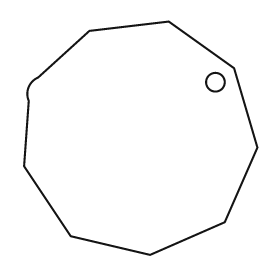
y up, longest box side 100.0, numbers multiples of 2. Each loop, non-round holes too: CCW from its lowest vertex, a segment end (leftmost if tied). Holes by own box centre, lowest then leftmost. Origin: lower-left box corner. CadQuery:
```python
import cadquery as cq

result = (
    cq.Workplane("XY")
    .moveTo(54.0, 0.0)
    .lineTo(86.0, 14.0)
    .lineTo(100.0, 46.0)
    .lineTo(90.0, 80.0)
    .lineTo(62.0, 100.0)
    .lineTo(28.0, 96.0)
    .lineTo(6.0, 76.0)
    .threePointArc((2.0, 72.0), (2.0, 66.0))
    .lineTo(0.0, 38.0)
    .lineTo(20.0, 8.0)
    .close()
    .moveTo(82.0, 74.0)
    .circle(4.0)
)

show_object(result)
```